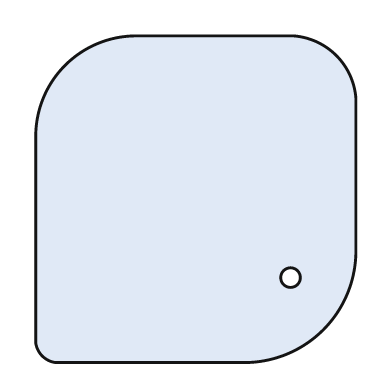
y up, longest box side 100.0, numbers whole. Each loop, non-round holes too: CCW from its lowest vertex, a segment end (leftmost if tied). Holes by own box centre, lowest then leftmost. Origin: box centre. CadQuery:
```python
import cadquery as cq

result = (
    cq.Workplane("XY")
    .moveTo(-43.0, -50.0)
    .lineTo(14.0, -50.0)
    .threePointArc((39.0, -40.0), (49.0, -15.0))
    .lineTo(49.0, 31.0)
    .threePointArc((43.0, 44.0), (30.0, 50.0))
    .lineTo(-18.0, 50.0)
    .threePointArc((-40.0, 41.0), (-49.0, 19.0))
    .lineTo(-49.0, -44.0)
    .threePointArc((-47.0, -48.0), (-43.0, -50.0))
    .close()
    .moveTo(29.0, -24.0)
    .circle(3.0)
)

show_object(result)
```